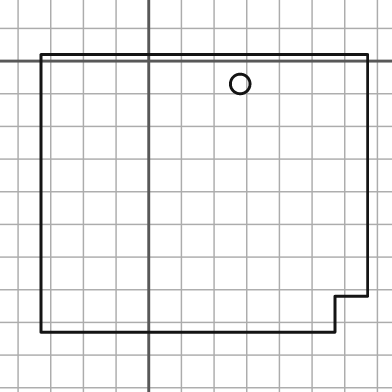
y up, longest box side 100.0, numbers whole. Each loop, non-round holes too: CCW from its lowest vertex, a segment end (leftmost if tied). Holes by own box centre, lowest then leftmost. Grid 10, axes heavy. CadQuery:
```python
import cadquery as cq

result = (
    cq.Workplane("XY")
    .moveTo(-33.0, -83.0)
    .lineTo(57.0, -83.0)
    .lineTo(57.0, -72.0)
    .lineTo(67.0, -72.0)
    .lineTo(67.0, 2.0)
    .lineTo(-33.0, 2.0)
    .close()
    .moveTo(28.0, -7.0)
    .circle(3.0)
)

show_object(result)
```